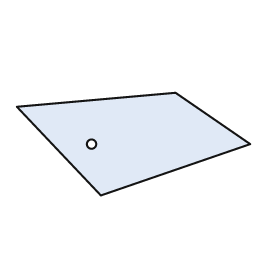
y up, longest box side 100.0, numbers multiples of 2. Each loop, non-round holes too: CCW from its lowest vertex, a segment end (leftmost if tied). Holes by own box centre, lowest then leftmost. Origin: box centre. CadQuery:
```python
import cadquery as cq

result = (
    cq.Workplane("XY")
    .moveTo(-14.0, -22.0)
    .lineTo(50.0, 0.0)
    .lineTo(18.0, 22.0)
    .lineTo(-50.0, 16.0)
    .close()
    .moveTo(-18.0, 0.0)
    .circle(2.0)
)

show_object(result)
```